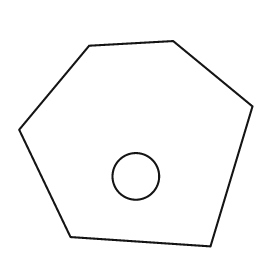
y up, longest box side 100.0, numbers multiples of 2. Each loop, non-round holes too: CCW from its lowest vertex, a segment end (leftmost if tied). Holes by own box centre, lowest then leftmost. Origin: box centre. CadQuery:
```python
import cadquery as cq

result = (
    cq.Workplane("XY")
    .moveTo(32.0, -44.0)
    .lineTo(50.0, 16.0)
    .lineTo(16.0, 44.0)
    .lineTo(-20.0, 42.0)
    .lineTo(-50.0, 6.0)
    .lineTo(-28.0, -40.0)
    .close()
    .moveTo(0.0, -14.0)
    .circle(10.0)
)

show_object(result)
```